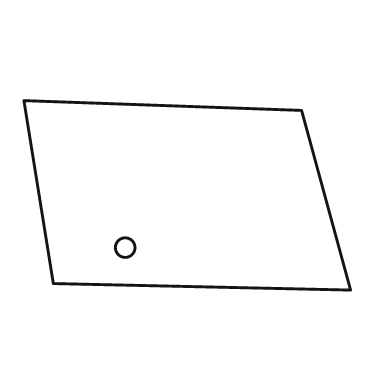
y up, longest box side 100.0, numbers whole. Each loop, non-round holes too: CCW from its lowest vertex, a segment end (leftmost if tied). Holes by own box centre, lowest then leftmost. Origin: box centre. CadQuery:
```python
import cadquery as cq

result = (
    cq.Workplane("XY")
    .moveTo(50.0, -29.0)
    .lineTo(35.0, 26.0)
    .lineTo(-50.0, 29.0)
    .lineTo(-41.0, -27.0)
    .close()
    .moveTo(-19.0, -16.0)
    .circle(3.0)
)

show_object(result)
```